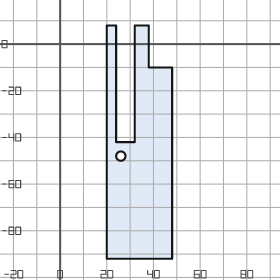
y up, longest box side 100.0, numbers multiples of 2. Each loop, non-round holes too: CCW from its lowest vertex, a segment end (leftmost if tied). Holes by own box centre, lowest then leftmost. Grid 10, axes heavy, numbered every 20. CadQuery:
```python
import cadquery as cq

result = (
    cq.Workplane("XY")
    .moveTo(20.0, -92.0)
    .lineTo(48.0, -92.0)
    .lineTo(48.0, -10.0)
    .lineTo(38.0, -10.0)
    .lineTo(38.0, 8.0)
    .lineTo(32.0, 8.0)
    .lineTo(32.0, -42.0)
    .lineTo(24.0, -42.0)
    .lineTo(24.0, 8.0)
    .lineTo(20.0, 8.0)
    .close()
    .moveTo(26.0, -48.0)
    .circle(2.0)
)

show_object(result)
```